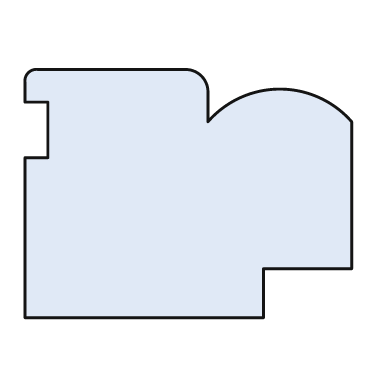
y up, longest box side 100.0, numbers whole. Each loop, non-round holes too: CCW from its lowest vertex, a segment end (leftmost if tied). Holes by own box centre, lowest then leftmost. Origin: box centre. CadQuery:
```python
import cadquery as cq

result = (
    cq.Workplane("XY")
    .moveTo(-50.0, -38.0)
    .lineTo(23.0, -38.0)
    .lineTo(23.0, -23.0)
    .lineTo(50.0, -23.0)
    .lineTo(50.0, 22.0)
    .threePointArc((28.0, 32.0), (6.0, 22.0))
    .lineTo(6.0, 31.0)
    .threePointArc((4.0, 36.0), (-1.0, 38.0))
    .lineTo(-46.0, 38.0)
    .threePointArc((-49.0, 37.0), (-50.0, 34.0))
    .lineTo(-50.0, 28.0)
    .lineTo(-43.0, 28.0)
    .lineTo(-43.0, 11.0)
    .lineTo(-50.0, 11.0)
    .close()
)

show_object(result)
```